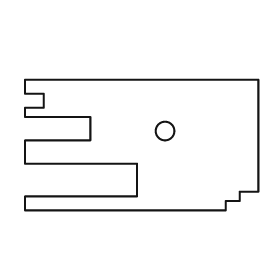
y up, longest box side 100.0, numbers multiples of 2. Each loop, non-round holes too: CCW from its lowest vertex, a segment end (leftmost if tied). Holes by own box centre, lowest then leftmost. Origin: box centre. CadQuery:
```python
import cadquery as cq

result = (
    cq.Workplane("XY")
    .moveTo(-50.0, -28.0)
    .lineTo(36.0, -28.0)
    .lineTo(36.0, -24.0)
    .lineTo(42.0, -24.0)
    .lineTo(42.0, -20.0)
    .lineTo(50.0, -20.0)
    .lineTo(50.0, 28.0)
    .lineTo(-50.0, 28.0)
    .lineTo(-50.0, 22.0)
    .lineTo(-42.0, 22.0)
    .lineTo(-42.0, 16.0)
    .lineTo(-50.0, 16.0)
    .lineTo(-50.0, 12.0)
    .lineTo(-22.0, 12.0)
    .lineTo(-22.0, 2.0)
    .lineTo(-50.0, 2.0)
    .lineTo(-50.0, -8.0)
    .lineTo(-2.0, -8.0)
    .lineTo(-2.0, -22.0)
    .lineTo(-50.0, -22.0)
    .close()
    .moveTo(10.0, 6.0)
    .circle(4.0)
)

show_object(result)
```